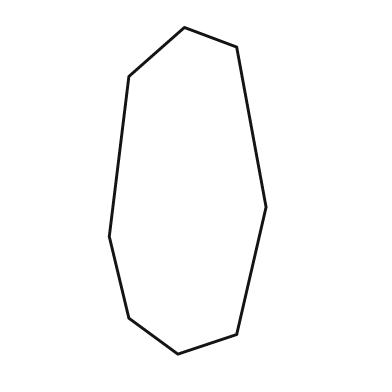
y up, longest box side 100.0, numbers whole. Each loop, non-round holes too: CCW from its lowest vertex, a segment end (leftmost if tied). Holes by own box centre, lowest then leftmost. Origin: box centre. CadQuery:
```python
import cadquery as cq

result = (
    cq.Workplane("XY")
    .moveTo(-3.0, -50.0)
    .lineTo(15.0, -44.0)
    .lineTo(24.0, -5.0)
    .lineTo(15.0, 44.0)
    .lineTo(-1.0, 50.0)
    .lineTo(-18.0, 35.0)
    .lineTo(-24.0, -14.0)
    .lineTo(-18.0, -39.0)
    .close()
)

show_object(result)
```